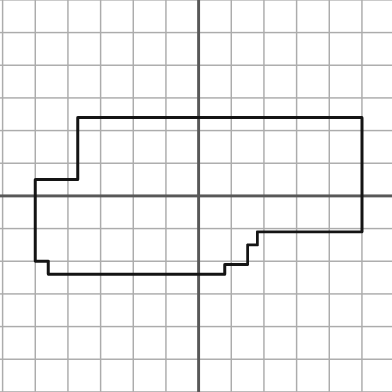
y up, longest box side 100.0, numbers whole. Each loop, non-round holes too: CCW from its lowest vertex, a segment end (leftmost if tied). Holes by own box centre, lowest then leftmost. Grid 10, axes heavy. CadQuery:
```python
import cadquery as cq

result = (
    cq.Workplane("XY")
    .moveTo(-46.0, -24.0)
    .lineTo(8.0, -24.0)
    .lineTo(8.0, -21.0)
    .lineTo(15.0, -21.0)
    .lineTo(15.0, -15.0)
    .lineTo(18.0, -15.0)
    .lineTo(18.0, -11.0)
    .lineTo(50.0, -11.0)
    .lineTo(50.0, 24.0)
    .lineTo(-37.0, 24.0)
    .lineTo(-37.0, 5.0)
    .lineTo(-50.0, 5.0)
    .lineTo(-50.0, -20.0)
    .lineTo(-46.0, -20.0)
    .close()
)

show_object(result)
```